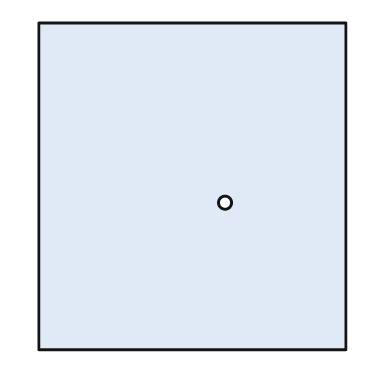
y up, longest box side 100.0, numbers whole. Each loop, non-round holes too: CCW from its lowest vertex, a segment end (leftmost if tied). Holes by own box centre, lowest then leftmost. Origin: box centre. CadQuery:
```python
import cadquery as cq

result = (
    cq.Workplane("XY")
    .moveTo(-47.0, -50.0)
    .lineTo(47.0, -50.0)
    .lineTo(47.0, 50.0)
    .lineTo(-47.0, 50.0)
    .close()
    .moveTo(10.0, -5.0)
    .circle(2.0)
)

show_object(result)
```